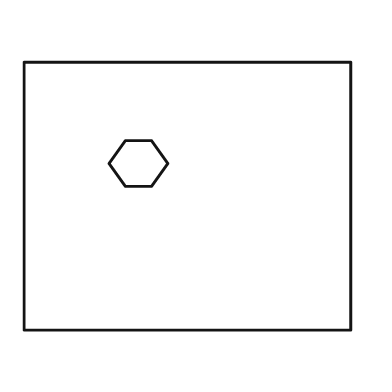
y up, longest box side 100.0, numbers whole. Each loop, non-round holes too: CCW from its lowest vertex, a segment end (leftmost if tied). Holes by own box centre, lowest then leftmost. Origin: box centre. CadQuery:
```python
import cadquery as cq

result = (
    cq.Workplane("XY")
    .moveTo(-50.0, -41.0)
    .lineTo(50.0, -41.0)
    .lineTo(50.0, 41.0)
    .lineTo(-50.0, 41.0)
    .close()
    .moveTo(-19.0, 3.0)
    .lineTo(-11.0, 3.0)
    .lineTo(-6.0, 10.0)
    .lineTo(-11.0, 17.0)
    .lineTo(-19.0, 17.0)
    .lineTo(-24.0, 10.0)
    .close()
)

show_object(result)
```